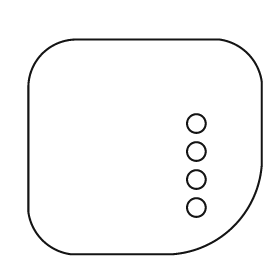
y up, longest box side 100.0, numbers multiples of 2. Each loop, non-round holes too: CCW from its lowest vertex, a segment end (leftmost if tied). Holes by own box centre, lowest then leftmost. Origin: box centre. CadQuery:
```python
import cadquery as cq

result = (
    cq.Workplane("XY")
    .moveTo(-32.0, -46.0)
    .lineTo(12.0, -46.0)
    .threePointArc((38.0, -34.0), (50.0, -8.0))
    .lineTo(50.0, 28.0)
    .threePointArc((44.0, 40.0), (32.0, 46.0))
    .lineTo(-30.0, 46.0)
    .threePointArc((-44.0, 40.0), (-50.0, 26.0))
    .lineTo(-50.0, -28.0)
    .threePointArc((-44.0, -40.0), (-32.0, -46.0))
    .close()
    .moveTo(22.0, -26.0)
    .circle(4.0)
    .moveTo(22.0, -14.0)
    .circle(4.0)
    .moveTo(22.0, -2.0)
    .circle(4.0)
    .moveTo(22.0, 10.0)
    .circle(4.0)
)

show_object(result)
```